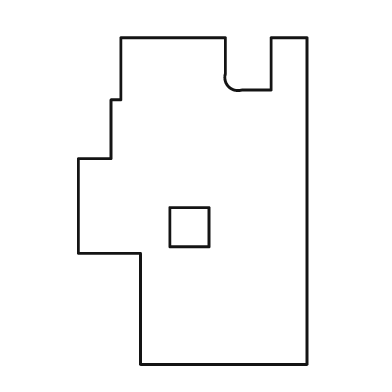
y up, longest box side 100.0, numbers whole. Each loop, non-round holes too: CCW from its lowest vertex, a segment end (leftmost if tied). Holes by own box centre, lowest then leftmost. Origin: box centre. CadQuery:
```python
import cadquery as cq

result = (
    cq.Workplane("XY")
    .moveTo(-16.0, -50.0)
    .lineTo(35.0, -50.0)
    .lineTo(35.0, 50.0)
    .lineTo(24.0, 50.0)
    .lineTo(24.0, 34.0)
    .lineTo(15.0, 34.0)
    .threePointArc((11.0, 35.0), (10.0, 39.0))
    .lineTo(10.0, 50.0)
    .lineTo(-22.0, 50.0)
    .lineTo(-22.0, 31.0)
    .lineTo(-25.0, 31.0)
    .lineTo(-25.0, 13.0)
    .lineTo(-35.0, 13.0)
    .lineTo(-35.0, -16.0)
    .lineTo(-16.0, -16.0)
    .close()
    .moveTo(-7.0, -14.0)
    .lineTo(5.0, -14.0)
    .lineTo(5.0, -2.0)
    .lineTo(-7.0, -2.0)
    .close()
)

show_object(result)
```